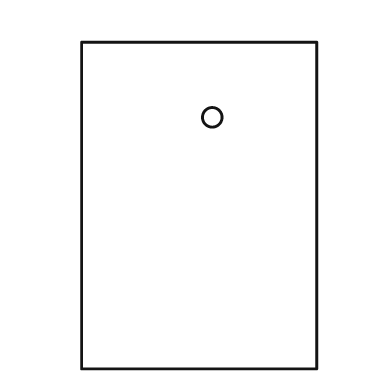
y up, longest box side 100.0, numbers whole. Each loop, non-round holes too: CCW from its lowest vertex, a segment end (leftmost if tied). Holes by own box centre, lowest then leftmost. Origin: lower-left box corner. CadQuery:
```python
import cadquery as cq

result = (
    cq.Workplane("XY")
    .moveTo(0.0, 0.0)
    .lineTo(72.0, 0.0)
    .lineTo(72.0, 100.0)
    .lineTo(0.0, 100.0)
    .close()
    .moveTo(40.0, 77.0)
    .circle(3.0)
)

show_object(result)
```